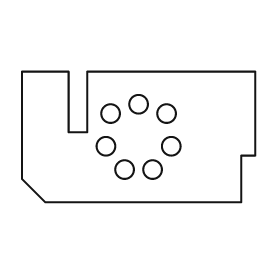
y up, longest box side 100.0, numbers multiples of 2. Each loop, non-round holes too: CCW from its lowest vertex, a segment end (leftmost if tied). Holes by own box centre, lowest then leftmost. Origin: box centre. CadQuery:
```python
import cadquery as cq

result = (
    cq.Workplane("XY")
    .moveTo(-40.0, -28.0)
    .lineTo(44.0, -28.0)
    .lineTo(44.0, -8.0)
    .lineTo(50.0, -8.0)
    .lineTo(50.0, 28.0)
    .lineTo(-22.0, 28.0)
    .lineTo(-22.0, 2.0)
    .lineTo(-30.0, 2.0)
    .lineTo(-30.0, 28.0)
    .lineTo(-50.0, 28.0)
    .lineTo(-50.0, -18.0)
    .close()
    .moveTo(-6.0, -14.0)
    .circle(4.0)
    .moveTo(6.0, -14.0)
    .circle(4.0)
    .moveTo(-14.0, -4.0)
    .circle(4.0)
    .moveTo(14.0, -4.0)
    .circle(4.0)
    .moveTo(-12.0, 10.0)
    .circle(4.0)
    .moveTo(12.0, 10.0)
    .circle(4.0)
    .moveTo(0.0, 14.0)
    .circle(4.0)
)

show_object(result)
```